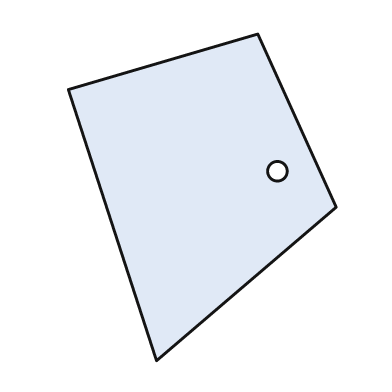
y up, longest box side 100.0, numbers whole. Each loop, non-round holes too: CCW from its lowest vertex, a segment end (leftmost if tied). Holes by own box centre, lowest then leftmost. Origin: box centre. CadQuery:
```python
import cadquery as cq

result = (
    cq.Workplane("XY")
    .moveTo(-14.0, -50.0)
    .lineTo(41.0, -3.0)
    .lineTo(17.0, 50.0)
    .lineTo(-41.0, 33.0)
    .close()
    .moveTo(23.0, 8.0)
    .circle(3.0)
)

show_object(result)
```